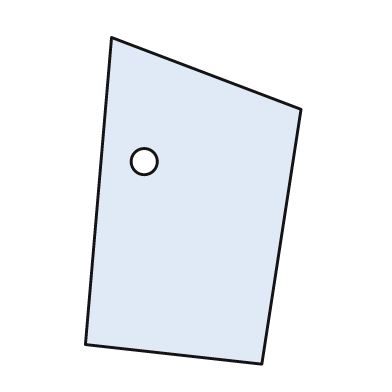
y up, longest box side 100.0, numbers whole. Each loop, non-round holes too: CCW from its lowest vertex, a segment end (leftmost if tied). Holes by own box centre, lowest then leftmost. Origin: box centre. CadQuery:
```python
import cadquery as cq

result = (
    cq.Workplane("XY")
    .moveTo(21.0, -50.0)
    .lineTo(33.0, 28.0)
    .lineTo(-25.0, 50.0)
    .lineTo(-33.0, -44.0)
    .close()
    .moveTo(-15.0, 12.0)
    .circle(4.0)
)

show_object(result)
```